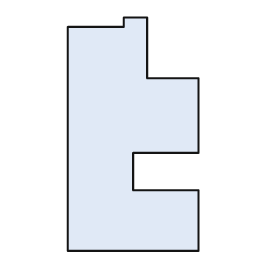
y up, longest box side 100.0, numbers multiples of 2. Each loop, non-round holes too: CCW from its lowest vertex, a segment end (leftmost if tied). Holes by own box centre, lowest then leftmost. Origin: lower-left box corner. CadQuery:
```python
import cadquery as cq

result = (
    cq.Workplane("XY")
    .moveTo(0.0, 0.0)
    .lineTo(56.0, 0.0)
    .lineTo(56.0, 26.0)
    .lineTo(28.0, 26.0)
    .lineTo(28.0, 42.0)
    .lineTo(56.0, 42.0)
    .lineTo(56.0, 74.0)
    .lineTo(34.0, 74.0)
    .lineTo(34.0, 100.0)
    .lineTo(24.0, 100.0)
    .lineTo(24.0, 96.0)
    .lineTo(0.0, 96.0)
    .close()
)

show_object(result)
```